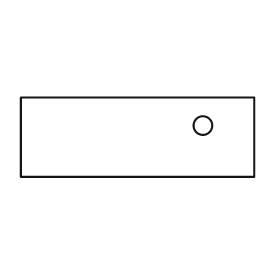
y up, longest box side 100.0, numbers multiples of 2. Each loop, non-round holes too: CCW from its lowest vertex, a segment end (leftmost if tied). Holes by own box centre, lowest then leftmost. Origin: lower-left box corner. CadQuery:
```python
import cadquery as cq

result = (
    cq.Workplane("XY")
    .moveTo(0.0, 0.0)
    .lineTo(100.0, 0.0)
    .lineTo(100.0, 34.0)
    .lineTo(0.0, 34.0)
    .close()
    .moveTo(78.0, 22.0)
    .circle(4.0)
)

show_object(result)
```